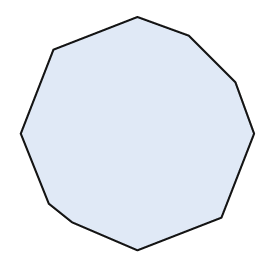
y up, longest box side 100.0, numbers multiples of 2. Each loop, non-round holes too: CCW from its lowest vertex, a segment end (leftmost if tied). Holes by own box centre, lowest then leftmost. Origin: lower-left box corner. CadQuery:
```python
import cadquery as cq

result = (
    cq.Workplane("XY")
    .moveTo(50.0, 0.0)
    .lineTo(86.0, 14.0)
    .lineTo(100.0, 50.0)
    .lineTo(92.0, 72.0)
    .lineTo(72.0, 92.0)
    .lineTo(50.0, 100.0)
    .lineTo(14.0, 86.0)
    .lineTo(0.0, 50.0)
    .lineTo(12.0, 20.0)
    .lineTo(22.0, 12.0)
    .close()
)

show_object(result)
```